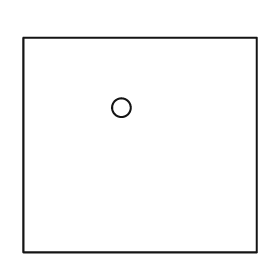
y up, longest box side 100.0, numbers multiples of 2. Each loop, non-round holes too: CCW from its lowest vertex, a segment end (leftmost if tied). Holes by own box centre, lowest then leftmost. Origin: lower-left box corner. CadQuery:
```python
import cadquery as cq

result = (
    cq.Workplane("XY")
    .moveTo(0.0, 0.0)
    .lineTo(100.0, 0.0)
    .lineTo(100.0, 92.0)
    .lineTo(0.0, 92.0)
    .close()
    .moveTo(42.0, 62.0)
    .circle(4.0)
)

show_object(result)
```